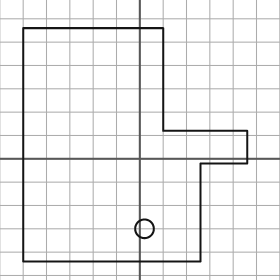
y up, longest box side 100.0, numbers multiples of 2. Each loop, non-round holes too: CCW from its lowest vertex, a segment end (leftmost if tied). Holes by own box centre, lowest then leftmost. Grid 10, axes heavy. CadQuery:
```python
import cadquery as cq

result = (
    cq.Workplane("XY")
    .moveTo(-50.0, -44.0)
    .lineTo(26.0, -44.0)
    .lineTo(26.0, -2.0)
    .lineTo(46.0, -2.0)
    .lineTo(46.0, 12.0)
    .lineTo(10.0, 12.0)
    .lineTo(10.0, 56.0)
    .lineTo(-50.0, 56.0)
    .close()
    .moveTo(2.0, -30.0)
    .circle(4.0)
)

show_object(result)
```